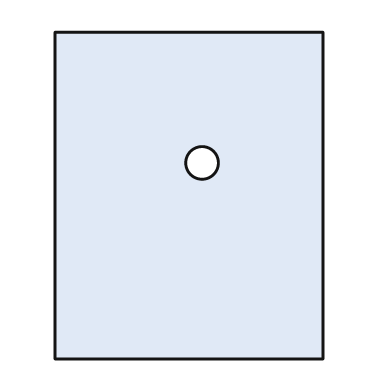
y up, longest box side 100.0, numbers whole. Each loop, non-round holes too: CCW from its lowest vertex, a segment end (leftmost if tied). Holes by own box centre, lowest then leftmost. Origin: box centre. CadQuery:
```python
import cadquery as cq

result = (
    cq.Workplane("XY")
    .moveTo(-41.0, -50.0)
    .lineTo(41.0, -50.0)
    .lineTo(41.0, 50.0)
    .lineTo(-41.0, 50.0)
    .close()
    .moveTo(4.0, 10.0)
    .circle(5.0)
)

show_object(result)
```